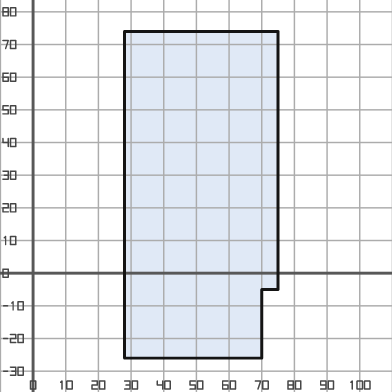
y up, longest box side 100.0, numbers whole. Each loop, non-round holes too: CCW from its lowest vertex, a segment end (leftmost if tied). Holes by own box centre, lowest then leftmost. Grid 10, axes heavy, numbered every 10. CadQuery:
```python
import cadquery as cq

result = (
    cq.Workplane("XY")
    .moveTo(28.0, -26.0)
    .lineTo(70.0, -26.0)
    .lineTo(70.0, -5.0)
    .lineTo(75.0, -5.0)
    .lineTo(75.0, 74.0)
    .lineTo(28.0, 74.0)
    .close()
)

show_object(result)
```